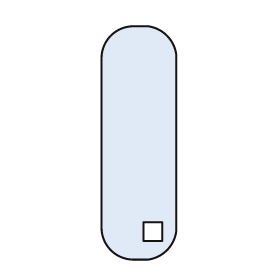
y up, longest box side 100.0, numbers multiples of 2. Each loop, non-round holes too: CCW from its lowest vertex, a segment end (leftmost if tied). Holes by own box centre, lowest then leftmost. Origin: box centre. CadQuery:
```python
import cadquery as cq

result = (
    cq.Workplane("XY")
    .moveTo(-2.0, -50.0)
    .lineTo(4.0, -50.0)
    .threePointArc((12.0, -46.0), (16.0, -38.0))
    .lineTo(16.0, 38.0)
    .threePointArc((12.0, 46.0), (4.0, 50.0))
    .lineTo(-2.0, 50.0)
    .threePointArc((-12.0, 46.0), (-16.0, 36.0))
    .lineTo(-16.0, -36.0)
    .threePointArc((-12.0, -46.0), (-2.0, -50.0))
    .close()
    .moveTo(2.0, -42.0)
    .lineTo(10.0, -42.0)
    .lineTo(10.0, -34.0)
    .lineTo(2.0, -34.0)
    .close()
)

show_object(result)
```